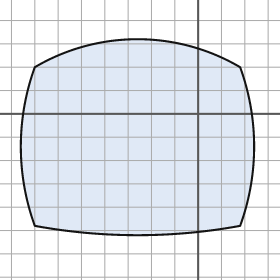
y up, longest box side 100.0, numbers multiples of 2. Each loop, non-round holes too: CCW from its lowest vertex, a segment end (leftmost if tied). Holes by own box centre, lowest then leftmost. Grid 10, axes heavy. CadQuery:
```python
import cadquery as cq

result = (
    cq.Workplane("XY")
    .moveTo(-70.0, -48.0)
    .threePointArc((-26.0, -52.0), (18.0, -48.0))
    .threePointArc((24.0, -14.0), (18.0, 20.0))
    .threePointArc((-26.0, 32.0), (-70.0, 20.0))
    .threePointArc((-76.0, -14.0), (-70.0, -48.0))
    .close()
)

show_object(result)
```